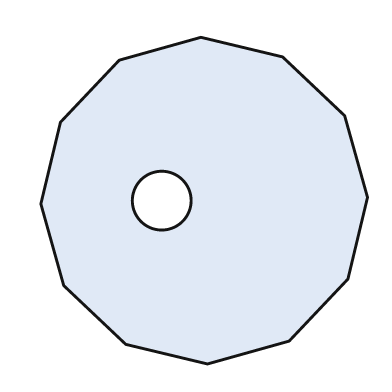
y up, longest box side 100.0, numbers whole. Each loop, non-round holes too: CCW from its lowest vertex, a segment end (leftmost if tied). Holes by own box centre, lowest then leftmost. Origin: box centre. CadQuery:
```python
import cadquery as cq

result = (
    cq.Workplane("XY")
    .moveTo(1.0, -50.0)
    .lineTo(26.0, -43.0)
    .lineTo(44.0, -24.0)
    .lineTo(50.0, 1.0)
    .lineTo(43.0, 26.0)
    .lineTo(24.0, 44.0)
    .lineTo(-1.0, 50.0)
    .lineTo(-26.0, 43.0)
    .lineTo(-44.0, 24.0)
    .lineTo(-50.0, -1.0)
    .lineTo(-43.0, -26.0)
    .lineTo(-24.0, -44.0)
    .close()
    .moveTo(-13.0, 0.0)
    .circle(9.0)
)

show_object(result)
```